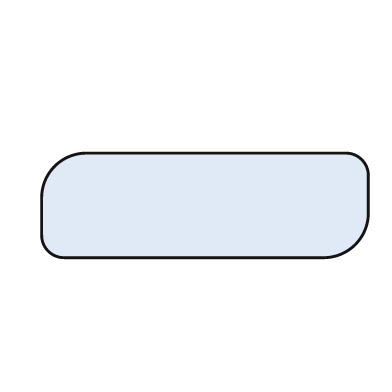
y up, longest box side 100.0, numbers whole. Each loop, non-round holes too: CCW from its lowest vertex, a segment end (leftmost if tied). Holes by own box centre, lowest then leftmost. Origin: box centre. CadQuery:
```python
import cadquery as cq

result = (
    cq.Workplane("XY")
    .moveTo(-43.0, -16.0)
    .lineTo(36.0, -16.0)
    .threePointArc((46.0, -12.0), (50.0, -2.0))
    .lineTo(50.0, 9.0)
    .threePointArc((48.0, 14.0), (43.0, 16.0))
    .lineTo(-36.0, 16.0)
    .threePointArc((-46.0, 12.0), (-50.0, 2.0))
    .lineTo(-50.0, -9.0)
    .threePointArc((-48.0, -14.0), (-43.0, -16.0))
    .close()
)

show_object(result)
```